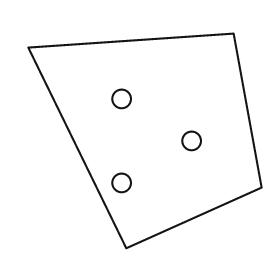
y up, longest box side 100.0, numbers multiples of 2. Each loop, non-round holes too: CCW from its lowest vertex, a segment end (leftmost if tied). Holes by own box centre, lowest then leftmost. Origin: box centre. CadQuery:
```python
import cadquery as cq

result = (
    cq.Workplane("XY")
    .moveTo(-8.0, -46.0)
    .lineTo(50.0, -20.0)
    .lineTo(38.0, 46.0)
    .lineTo(-50.0, 40.0)
    .close()
    .moveTo(-10.0, -18.0)
    .circle(4.0)
    .moveTo(20.0, 0.0)
    .circle(4.0)
    .moveTo(-10.0, 18.0)
    .circle(4.0)
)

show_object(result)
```